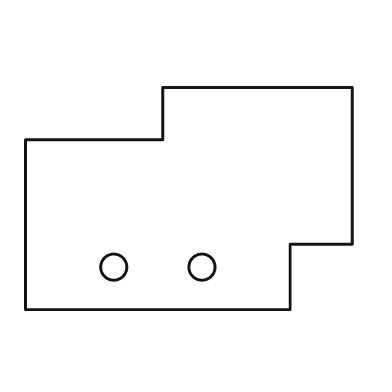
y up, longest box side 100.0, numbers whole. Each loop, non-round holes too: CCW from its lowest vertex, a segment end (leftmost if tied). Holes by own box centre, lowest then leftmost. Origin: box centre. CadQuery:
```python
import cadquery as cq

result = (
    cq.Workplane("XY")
    .moveTo(-50.0, -34.0)
    .lineTo(31.0, -34.0)
    .lineTo(31.0, -14.0)
    .lineTo(50.0, -14.0)
    .lineTo(50.0, 34.0)
    .lineTo(-8.0, 34.0)
    .lineTo(-8.0, 18.0)
    .lineTo(-50.0, 18.0)
    .close()
    .moveTo(-23.0, -21.0)
    .circle(4.0)
    .moveTo(4.0, -21.0)
    .circle(4.0)
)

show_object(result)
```